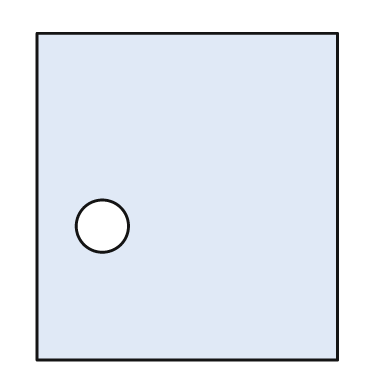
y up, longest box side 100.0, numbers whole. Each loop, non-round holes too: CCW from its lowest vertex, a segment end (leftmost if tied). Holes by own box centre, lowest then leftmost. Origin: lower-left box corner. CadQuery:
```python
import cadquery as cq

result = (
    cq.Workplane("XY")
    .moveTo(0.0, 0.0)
    .lineTo(92.0, 0.0)
    .lineTo(92.0, 100.0)
    .lineTo(0.0, 100.0)
    .close()
    .moveTo(20.0, 41.0)
    .circle(8.0)
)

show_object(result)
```